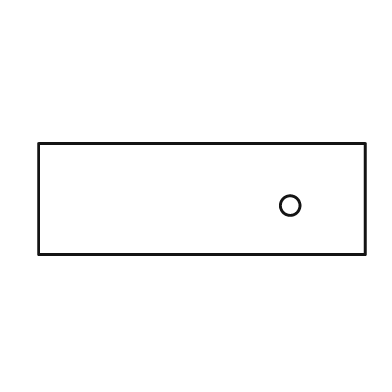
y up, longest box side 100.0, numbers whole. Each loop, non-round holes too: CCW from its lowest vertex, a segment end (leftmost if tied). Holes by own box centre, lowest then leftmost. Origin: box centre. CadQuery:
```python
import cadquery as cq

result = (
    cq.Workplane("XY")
    .moveTo(-50.0, -17.0)
    .lineTo(50.0, -17.0)
    .lineTo(50.0, 17.0)
    .lineTo(-50.0, 17.0)
    .close()
    .moveTo(27.0, -2.0)
    .circle(3.0)
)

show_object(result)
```